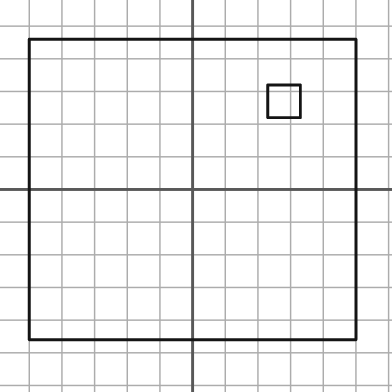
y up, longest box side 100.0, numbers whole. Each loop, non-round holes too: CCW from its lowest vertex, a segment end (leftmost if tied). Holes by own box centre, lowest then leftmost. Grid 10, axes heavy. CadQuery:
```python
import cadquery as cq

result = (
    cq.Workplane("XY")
    .moveTo(-50.0, -46.0)
    .lineTo(50.0, -46.0)
    .lineTo(50.0, 46.0)
    .lineTo(-50.0, 46.0)
    .close()
    .moveTo(23.0, 22.0)
    .lineTo(33.0, 22.0)
    .lineTo(33.0, 32.0)
    .lineTo(23.0, 32.0)
    .close()
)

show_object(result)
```